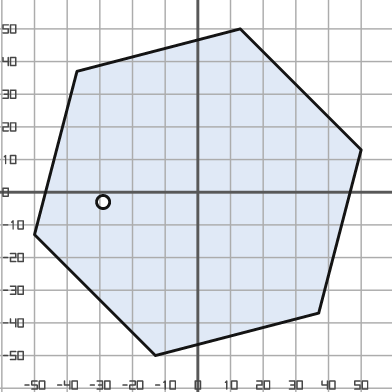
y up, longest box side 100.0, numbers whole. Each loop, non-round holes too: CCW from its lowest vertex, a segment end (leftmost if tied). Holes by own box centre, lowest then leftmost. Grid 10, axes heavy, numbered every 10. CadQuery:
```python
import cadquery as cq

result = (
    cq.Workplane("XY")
    .moveTo(-13.0, -50.0)
    .lineTo(37.0, -37.0)
    .lineTo(50.0, 13.0)
    .lineTo(13.0, 50.0)
    .lineTo(-37.0, 37.0)
    .lineTo(-50.0, -13.0)
    .close()
    .moveTo(-29.0, -3.0)
    .circle(2.0)
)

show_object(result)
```